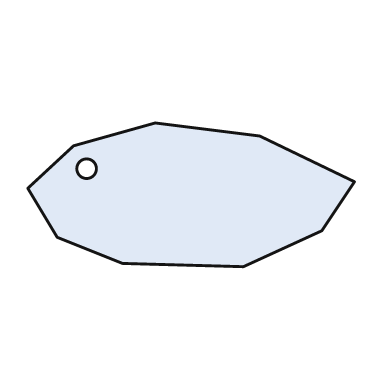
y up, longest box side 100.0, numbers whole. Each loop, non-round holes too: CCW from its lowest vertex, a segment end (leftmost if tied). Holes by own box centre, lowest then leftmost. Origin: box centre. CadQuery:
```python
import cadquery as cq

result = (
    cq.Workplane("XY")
    .moveTo(16.0, -22.0)
    .lineTo(40.0, -11.0)
    .lineTo(50.0, 4.0)
    .lineTo(21.0, 18.0)
    .lineTo(-11.0, 22.0)
    .lineTo(-36.0, 15.0)
    .lineTo(-50.0, 2.0)
    .lineTo(-41.0, -13.0)
    .lineTo(-21.0, -21.0)
    .close()
    .moveTo(-32.0, 8.0)
    .circle(3.0)
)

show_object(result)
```